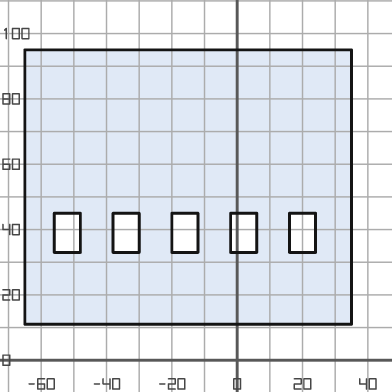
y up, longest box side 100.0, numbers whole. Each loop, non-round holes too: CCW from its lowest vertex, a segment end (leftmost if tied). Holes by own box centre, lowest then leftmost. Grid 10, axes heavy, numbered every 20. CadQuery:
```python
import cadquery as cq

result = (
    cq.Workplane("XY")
    .moveTo(-65.0, 11.0)
    .lineTo(35.0, 11.0)
    .lineTo(35.0, 95.0)
    .lineTo(-65.0, 95.0)
    .close()
    .moveTo(-56.0, 33.0)
    .lineTo(-48.0, 33.0)
    .lineTo(-48.0, 45.0)
    .lineTo(-56.0, 45.0)
    .close()
    .moveTo(-38.0, 33.0)
    .lineTo(-30.0, 33.0)
    .lineTo(-30.0, 45.0)
    .lineTo(-38.0, 45.0)
    .close()
    .moveTo(-20.0, 33.0)
    .lineTo(-12.0, 33.0)
    .lineTo(-12.0, 45.0)
    .lineTo(-20.0, 45.0)
    .close()
    .moveTo(-2.0, 33.0)
    .lineTo(6.0, 33.0)
    .lineTo(6.0, 45.0)
    .lineTo(-2.0, 45.0)
    .close()
    .moveTo(16.0, 33.0)
    .lineTo(24.0, 33.0)
    .lineTo(24.0, 45.0)
    .lineTo(16.0, 45.0)
    .close()
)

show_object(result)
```